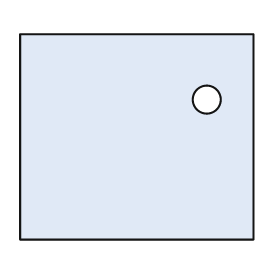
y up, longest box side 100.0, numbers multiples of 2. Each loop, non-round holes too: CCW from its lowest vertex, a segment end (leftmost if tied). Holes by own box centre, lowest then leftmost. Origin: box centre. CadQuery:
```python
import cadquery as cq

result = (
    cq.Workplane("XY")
    .moveTo(-50.0, -44.0)
    .lineTo(50.0, -44.0)
    .lineTo(50.0, 44.0)
    .lineTo(-50.0, 44.0)
    .close()
    .moveTo(30.0, 16.0)
    .circle(6.0)
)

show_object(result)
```